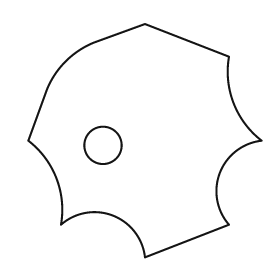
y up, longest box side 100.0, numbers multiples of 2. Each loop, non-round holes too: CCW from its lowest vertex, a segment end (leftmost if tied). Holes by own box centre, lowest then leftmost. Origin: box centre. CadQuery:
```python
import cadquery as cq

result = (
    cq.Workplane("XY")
    .moveTo(0.0, -50.0)
    .lineTo(36.0, -36.0)
    .threePointArc((32.0, -14.0), (50.0, 0.0))
    .threePointArc((38.0, 16.0), (36.0, 36.0))
    .lineTo(0.0, 50.0)
    .lineTo(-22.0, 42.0)
    .threePointArc((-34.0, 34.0), (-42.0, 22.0))
    .lineTo(-50.0, 0.0)
    .threePointArc((-38.0, -16.0), (-36.0, -36.0))
    .threePointArc((-14.0, -32.0), (0.0, -50.0))
    .close()
    .moveTo(-18.0, -2.0)
    .circle(8.0)
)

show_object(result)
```